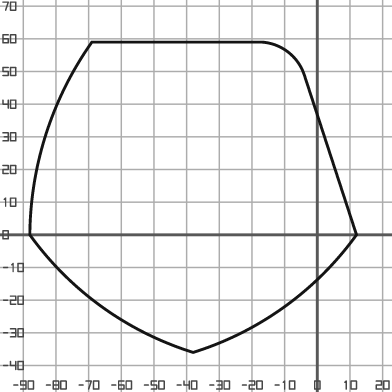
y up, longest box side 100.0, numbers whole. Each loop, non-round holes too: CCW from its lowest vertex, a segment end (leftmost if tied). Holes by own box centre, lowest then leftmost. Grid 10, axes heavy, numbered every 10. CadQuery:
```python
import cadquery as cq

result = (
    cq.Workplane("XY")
    .moveTo(-38.0, -36.0)
    .threePointArc((-10.0, -22.0), (12.0, 0.0))
    .lineTo(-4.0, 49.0)
    .threePointArc((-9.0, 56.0), (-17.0, 59.0))
    .lineTo(-69.0, 59.0)
    .threePointArc((-83.0, 31.0), (-88.0, 0.0))
    .threePointArc((-66.0, -22.0), (-38.0, -36.0))
    .close()
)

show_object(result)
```